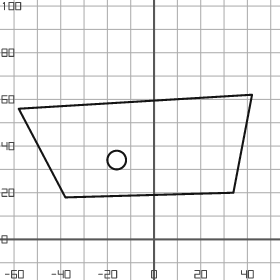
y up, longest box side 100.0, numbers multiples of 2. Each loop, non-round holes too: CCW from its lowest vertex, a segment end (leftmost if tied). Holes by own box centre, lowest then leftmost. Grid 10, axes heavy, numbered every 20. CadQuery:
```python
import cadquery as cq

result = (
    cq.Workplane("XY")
    .moveTo(-38.0, 18.0)
    .lineTo(34.0, 20.0)
    .lineTo(42.0, 62.0)
    .lineTo(-58.0, 56.0)
    .close()
    .moveTo(-16.0, 34.0)
    .circle(4.0)
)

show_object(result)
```